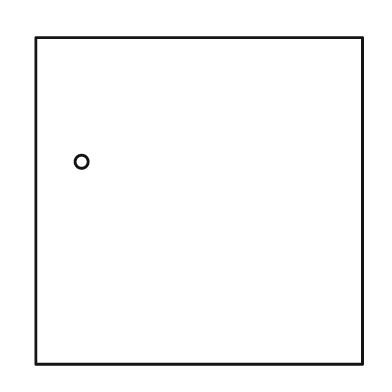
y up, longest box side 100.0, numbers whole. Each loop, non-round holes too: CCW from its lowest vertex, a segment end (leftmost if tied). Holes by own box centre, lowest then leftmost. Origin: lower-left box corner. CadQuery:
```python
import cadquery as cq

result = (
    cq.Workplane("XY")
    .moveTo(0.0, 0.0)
    .lineTo(100.0, 0.0)
    .lineTo(100.0, 100.0)
    .lineTo(0.0, 100.0)
    .close()
    .moveTo(14.0, 62.0)
    .circle(2.0)
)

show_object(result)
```